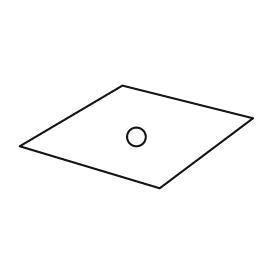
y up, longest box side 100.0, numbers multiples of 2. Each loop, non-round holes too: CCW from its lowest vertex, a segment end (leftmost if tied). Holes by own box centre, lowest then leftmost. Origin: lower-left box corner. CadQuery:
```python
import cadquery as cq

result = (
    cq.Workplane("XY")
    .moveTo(60.0, 0.0)
    .lineTo(100.0, 30.0)
    .lineTo(44.0, 44.0)
    .lineTo(0.0, 18.0)
    .close()
    .moveTo(50.0, 22.0)
    .circle(4.0)
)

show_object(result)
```